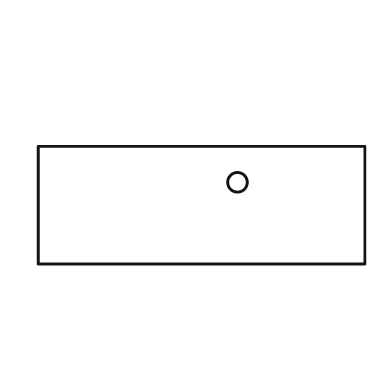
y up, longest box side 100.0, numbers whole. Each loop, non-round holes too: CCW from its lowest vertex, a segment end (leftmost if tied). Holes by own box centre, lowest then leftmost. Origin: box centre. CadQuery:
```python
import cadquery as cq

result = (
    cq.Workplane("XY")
    .moveTo(-50.0, -18.0)
    .lineTo(50.0, -18.0)
    .lineTo(50.0, 18.0)
    .lineTo(-50.0, 18.0)
    .close()
    .moveTo(11.0, 7.0)
    .circle(3.0)
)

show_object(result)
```